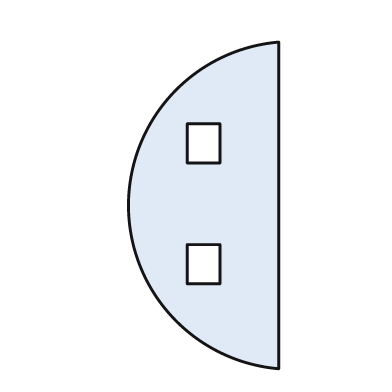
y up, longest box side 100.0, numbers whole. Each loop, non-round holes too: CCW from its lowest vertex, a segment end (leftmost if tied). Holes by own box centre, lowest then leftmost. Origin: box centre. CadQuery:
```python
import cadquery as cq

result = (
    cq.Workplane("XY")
    .moveTo(23.0, -50.0)
    .lineTo(23.0, 50.0)
    .threePointArc((-23.0, 0.0), (23.0, -50.0))
    .close()
    .moveTo(-5.0, -24.0)
    .lineTo(5.0, -24.0)
    .lineTo(5.0, -12.0)
    .lineTo(-5.0, -12.0)
    .close()
    .moveTo(-5.0, 13.0)
    .lineTo(5.0, 13.0)
    .lineTo(5.0, 25.0)
    .lineTo(-5.0, 25.0)
    .close()
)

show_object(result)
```